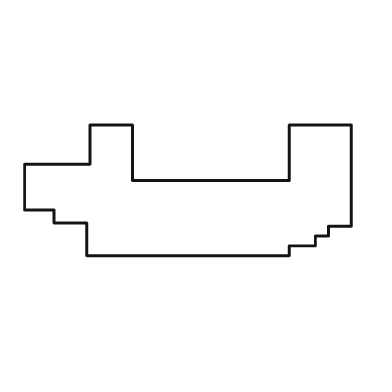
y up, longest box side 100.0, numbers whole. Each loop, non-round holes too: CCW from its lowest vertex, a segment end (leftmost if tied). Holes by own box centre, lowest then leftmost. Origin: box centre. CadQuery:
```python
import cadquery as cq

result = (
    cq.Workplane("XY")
    .moveTo(-31.0, -20.0)
    .lineTo(31.0, -20.0)
    .lineTo(31.0, -17.0)
    .lineTo(39.0, -17.0)
    .lineTo(39.0, -14.0)
    .lineTo(43.0, -14.0)
    .lineTo(43.0, -11.0)
    .lineTo(50.0, -11.0)
    .lineTo(50.0, 20.0)
    .lineTo(31.0, 20.0)
    .lineTo(31.0, 3.0)
    .lineTo(-17.0, 3.0)
    .lineTo(-17.0, 20.0)
    .lineTo(-30.0, 20.0)
    .lineTo(-30.0, 8.0)
    .lineTo(-50.0, 8.0)
    .lineTo(-50.0, -6.0)
    .lineTo(-41.0, -6.0)
    .lineTo(-41.0, -10.0)
    .lineTo(-31.0, -10.0)
    .close()
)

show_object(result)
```